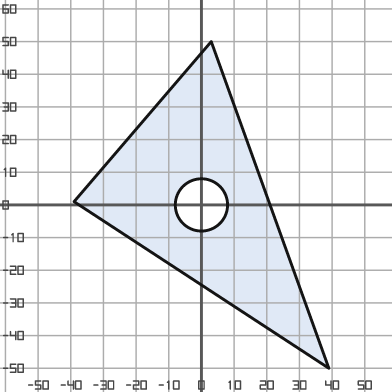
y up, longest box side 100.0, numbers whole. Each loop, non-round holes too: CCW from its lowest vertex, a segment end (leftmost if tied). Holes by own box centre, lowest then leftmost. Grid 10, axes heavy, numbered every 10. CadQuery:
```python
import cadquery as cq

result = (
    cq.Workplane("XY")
    .moveTo(39.0, -50.0)
    .lineTo(3.0, 50.0)
    .lineTo(-39.0, 1.0)
    .close()
    .moveTo(0.0, 0.0)
    .circle(8.0)
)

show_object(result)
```